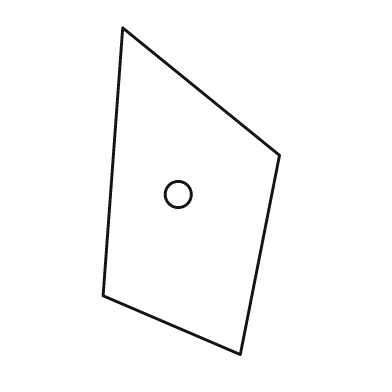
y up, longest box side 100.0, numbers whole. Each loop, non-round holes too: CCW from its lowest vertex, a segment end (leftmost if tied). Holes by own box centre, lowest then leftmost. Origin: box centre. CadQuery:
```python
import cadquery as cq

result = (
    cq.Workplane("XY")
    .moveTo(15.0, -50.0)
    .lineTo(27.0, 11.0)
    .lineTo(-21.0, 50.0)
    .lineTo(-27.0, -32.0)
    .close()
    .moveTo(-4.0, -1.0)
    .circle(4.0)
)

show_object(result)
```